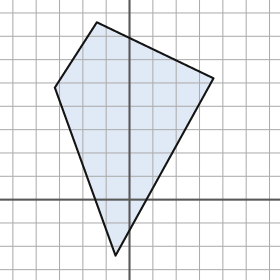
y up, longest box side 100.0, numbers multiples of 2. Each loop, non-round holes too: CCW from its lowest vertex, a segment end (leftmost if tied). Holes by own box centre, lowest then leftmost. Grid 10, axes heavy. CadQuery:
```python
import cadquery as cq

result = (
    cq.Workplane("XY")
    .moveTo(-6.0, -24.0)
    .lineTo(36.0, 52.0)
    .lineTo(-14.0, 76.0)
    .lineTo(-32.0, 48.0)
    .close()
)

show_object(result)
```